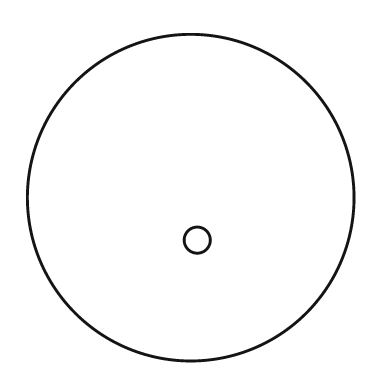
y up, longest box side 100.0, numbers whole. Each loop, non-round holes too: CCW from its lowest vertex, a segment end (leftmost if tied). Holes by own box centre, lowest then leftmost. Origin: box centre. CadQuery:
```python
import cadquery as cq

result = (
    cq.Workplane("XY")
    .moveTo(0.0, 0.0)
    .circle(50.0)
    .moveTo(2.0, -13.0)
    .circle(4.0)
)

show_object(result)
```